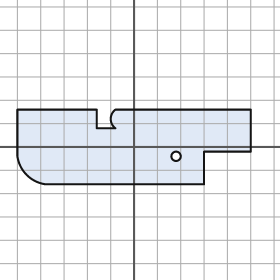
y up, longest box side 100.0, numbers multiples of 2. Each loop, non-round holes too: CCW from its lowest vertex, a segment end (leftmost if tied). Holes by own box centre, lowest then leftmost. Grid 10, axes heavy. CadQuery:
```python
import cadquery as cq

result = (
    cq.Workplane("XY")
    .moveTo(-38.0, -16.0)
    .lineTo(30.0, -16.0)
    .lineTo(30.0, -2.0)
    .lineTo(50.0, -2.0)
    .lineTo(50.0, 16.0)
    .lineTo(-8.0, 16.0)
    .threePointArc((-10.0, 12.0), (-8.0, 8.0))
    .lineTo(-16.0, 8.0)
    .lineTo(-16.0, 16.0)
    .lineTo(-50.0, 16.0)
    .lineTo(-50.0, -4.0)
    .threePointArc((-46.0, -12.0), (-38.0, -16.0))
    .close()
    .moveTo(18.0, -4.0)
    .circle(2.0)
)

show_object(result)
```